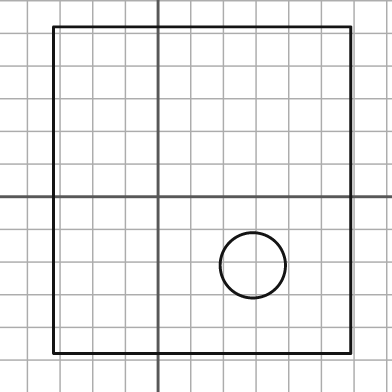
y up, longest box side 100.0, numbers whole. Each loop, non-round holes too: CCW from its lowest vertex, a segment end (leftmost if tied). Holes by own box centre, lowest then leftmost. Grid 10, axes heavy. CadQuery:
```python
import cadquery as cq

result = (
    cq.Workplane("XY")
    .moveTo(-32.0, -48.0)
    .lineTo(59.0, -48.0)
    .lineTo(59.0, 52.0)
    .lineTo(-32.0, 52.0)
    .close()
    .moveTo(29.0, -21.0)
    .circle(10.0)
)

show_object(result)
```